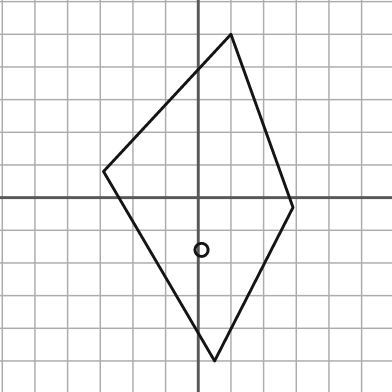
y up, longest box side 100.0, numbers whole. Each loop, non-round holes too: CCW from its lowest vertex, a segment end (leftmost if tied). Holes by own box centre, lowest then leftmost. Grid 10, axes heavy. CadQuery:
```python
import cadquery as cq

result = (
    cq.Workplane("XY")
    .moveTo(5.0, -50.0)
    .lineTo(29.0, -3.0)
    .lineTo(10.0, 50.0)
    .lineTo(-29.0, 8.0)
    .close()
    .moveTo(1.0, -16.0)
    .circle(2.0)
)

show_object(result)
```